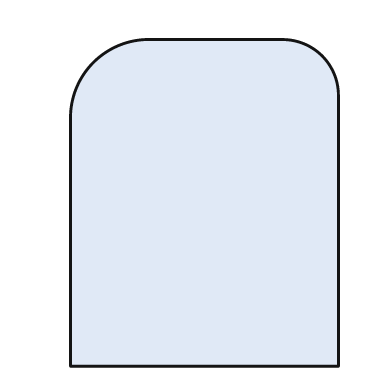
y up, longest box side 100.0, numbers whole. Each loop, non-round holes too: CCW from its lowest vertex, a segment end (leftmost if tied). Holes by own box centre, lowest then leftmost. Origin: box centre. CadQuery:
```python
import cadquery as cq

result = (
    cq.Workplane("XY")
    .moveTo(-41.0, -50.0)
    .lineTo(41.0, -50.0)
    .lineTo(41.0, 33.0)
    .threePointArc((36.0, 45.0), (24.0, 50.0))
    .lineTo(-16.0, 50.0)
    .threePointArc((-34.0, 43.0), (-41.0, 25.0))
    .close()
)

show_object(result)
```